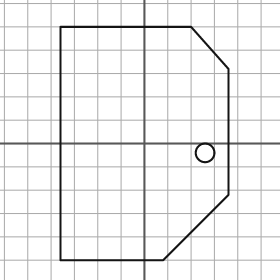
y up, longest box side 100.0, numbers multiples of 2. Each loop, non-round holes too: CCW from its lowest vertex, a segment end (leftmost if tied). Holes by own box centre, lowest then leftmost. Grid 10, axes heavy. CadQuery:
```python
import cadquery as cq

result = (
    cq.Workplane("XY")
    .moveTo(-36.0, -50.0)
    .lineTo(8.0, -50.0)
    .lineTo(36.0, -22.0)
    .lineTo(36.0, 32.0)
    .lineTo(20.0, 50.0)
    .lineTo(-36.0, 50.0)
    .close()
    .moveTo(26.0, -4.0)
    .circle(4.0)
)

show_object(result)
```